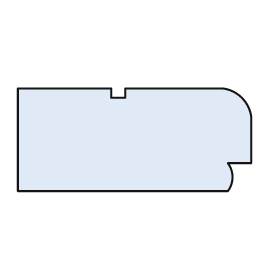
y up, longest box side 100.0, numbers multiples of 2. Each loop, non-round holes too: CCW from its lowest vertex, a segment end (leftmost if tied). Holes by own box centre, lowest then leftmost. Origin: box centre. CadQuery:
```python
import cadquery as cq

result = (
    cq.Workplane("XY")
    .moveTo(-50.0, -22.0)
    .lineTo(40.0, -22.0)
    .threePointArc((42.0, -16.0), (40.0, -10.0))
    .lineTo(50.0, -10.0)
    .lineTo(50.0, 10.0)
    .threePointArc((46.0, 18.0), (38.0, 22.0))
    .lineTo(-4.0, 22.0)
    .lineTo(-4.0, 18.0)
    .lineTo(-10.0, 18.0)
    .lineTo(-10.0, 22.0)
    .lineTo(-50.0, 22.0)
    .close()
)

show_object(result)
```